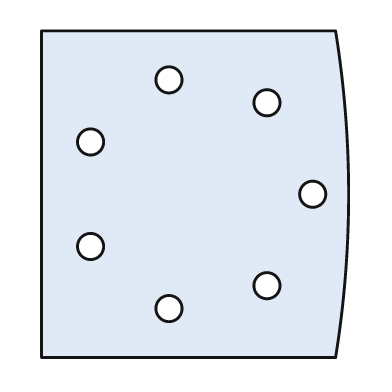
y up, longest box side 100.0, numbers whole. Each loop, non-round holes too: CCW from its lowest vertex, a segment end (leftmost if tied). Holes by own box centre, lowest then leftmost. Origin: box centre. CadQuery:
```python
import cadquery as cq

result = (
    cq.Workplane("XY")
    .moveTo(-47.0, -50.0)
    .lineTo(43.0, -50.0)
    .threePointArc((47.0, 0.0), (43.0, 50.0))
    .lineTo(-47.0, 50.0)
    .close()
    .moveTo(-8.0, -35.0)
    .circle(4.0)
    .moveTo(22.0, -28.0)
    .circle(4.0)
    .moveTo(-32.0, -16.0)
    .circle(4.0)
    .moveTo(36.0, 0.0)
    .circle(4.0)
    .moveTo(-32.0, 16.0)
    .circle(4.0)
    .moveTo(22.0, 28.0)
    .circle(4.0)
    .moveTo(-8.0, 35.0)
    .circle(4.0)
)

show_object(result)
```